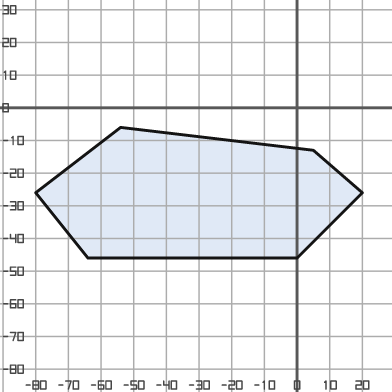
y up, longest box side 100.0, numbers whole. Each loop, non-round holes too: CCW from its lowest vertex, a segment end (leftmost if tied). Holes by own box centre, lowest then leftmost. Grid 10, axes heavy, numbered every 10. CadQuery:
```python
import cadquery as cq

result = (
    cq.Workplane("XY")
    .moveTo(-64.0, -46.0)
    .lineTo(0.0, -46.0)
    .lineTo(20.0, -26.0)
    .lineTo(5.0, -13.0)
    .lineTo(-54.0, -6.0)
    .lineTo(-80.0, -26.0)
    .close()
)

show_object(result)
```